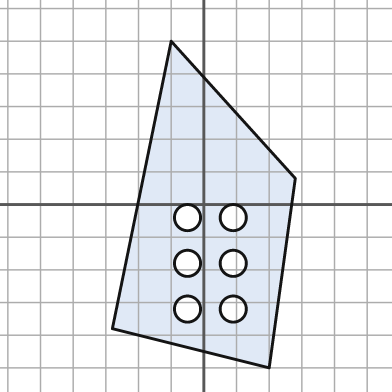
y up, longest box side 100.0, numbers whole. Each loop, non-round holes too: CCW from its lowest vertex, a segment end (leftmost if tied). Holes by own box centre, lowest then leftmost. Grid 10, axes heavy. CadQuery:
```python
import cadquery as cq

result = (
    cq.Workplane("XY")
    .moveTo(20.0, -50.0)
    .lineTo(28.0, 8.0)
    .lineTo(-10.0, 50.0)
    .lineTo(-28.0, -38.0)
    .close()
    .moveTo(-5.0, -32.0)
    .circle(4.0)
    .moveTo(9.0, -32.0)
    .circle(4.0)
    .moveTo(-5.0, -18.0)
    .circle(4.0)
    .moveTo(9.0, -18.0)
    .circle(4.0)
    .moveTo(-5.0, -4.0)
    .circle(4.0)
    .moveTo(9.0, -4.0)
    .circle(4.0)
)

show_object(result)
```